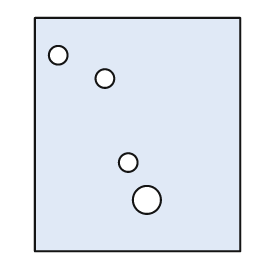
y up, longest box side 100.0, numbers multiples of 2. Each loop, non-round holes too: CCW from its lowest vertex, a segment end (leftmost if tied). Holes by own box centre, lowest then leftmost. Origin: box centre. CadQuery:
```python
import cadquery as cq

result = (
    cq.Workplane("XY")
    .moveTo(-44.0, -50.0)
    .lineTo(44.0, -50.0)
    .lineTo(44.0, 50.0)
    .lineTo(-44.0, 50.0)
    .close()
    .moveTo(4.0, -28.0)
    .circle(6.0)
    .moveTo(-4.0, -12.0)
    .circle(4.0)
    .moveTo(-14.0, 24.0)
    .circle(4.0)
    .moveTo(-34.0, 34.0)
    .circle(4.0)
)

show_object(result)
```